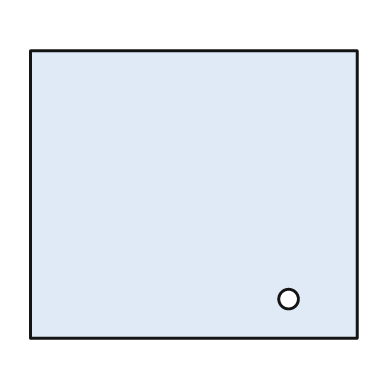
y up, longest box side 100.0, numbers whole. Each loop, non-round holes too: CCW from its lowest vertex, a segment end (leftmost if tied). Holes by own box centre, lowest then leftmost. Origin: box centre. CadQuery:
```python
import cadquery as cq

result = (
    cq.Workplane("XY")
    .moveTo(-50.0, -44.0)
    .lineTo(50.0, -44.0)
    .lineTo(50.0, 44.0)
    .lineTo(-50.0, 44.0)
    .close()
    .moveTo(29.0, -32.0)
    .circle(3.0)
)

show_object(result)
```